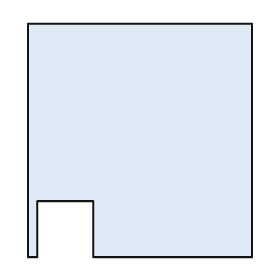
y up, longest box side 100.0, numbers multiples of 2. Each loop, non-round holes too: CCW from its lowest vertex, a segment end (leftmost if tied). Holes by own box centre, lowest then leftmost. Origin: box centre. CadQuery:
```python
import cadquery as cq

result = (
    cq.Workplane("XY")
    .moveTo(-48.0, -50.0)
    .lineTo(-44.0, -50.0)
    .lineTo(-44.0, -26.0)
    .lineTo(-20.0, -26.0)
    .lineTo(-20.0, -50.0)
    .lineTo(48.0, -50.0)
    .lineTo(48.0, 50.0)
    .lineTo(-48.0, 50.0)
    .close()
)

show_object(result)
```